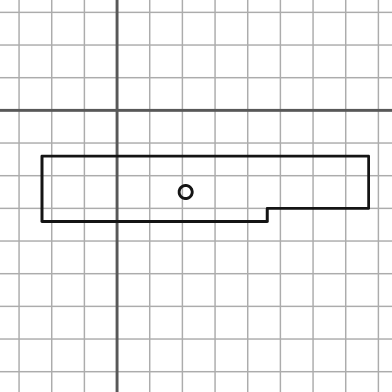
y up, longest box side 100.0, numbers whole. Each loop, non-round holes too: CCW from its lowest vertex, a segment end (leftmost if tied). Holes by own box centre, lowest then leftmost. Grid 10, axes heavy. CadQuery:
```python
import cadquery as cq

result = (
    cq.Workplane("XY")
    .moveTo(-23.0, -34.0)
    .lineTo(46.0, -34.0)
    .lineTo(46.0, -30.0)
    .lineTo(77.0, -30.0)
    .lineTo(77.0, -14.0)
    .lineTo(-23.0, -14.0)
    .close()
    .moveTo(21.0, -25.0)
    .circle(2.0)
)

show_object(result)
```